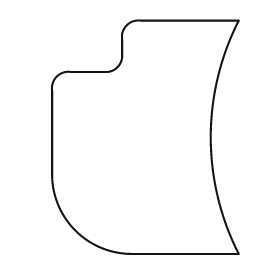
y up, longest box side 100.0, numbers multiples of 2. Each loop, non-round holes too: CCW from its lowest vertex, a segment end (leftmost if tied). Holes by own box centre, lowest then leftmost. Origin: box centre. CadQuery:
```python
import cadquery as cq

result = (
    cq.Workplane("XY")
    .moveTo(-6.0, -50.0)
    .lineTo(40.0, -50.0)
    .threePointArc((28.0, 0.0), (40.0, 50.0))
    .lineTo(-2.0, 50.0)
    .threePointArc((-8.0, 48.0), (-10.0, 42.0))
    .lineTo(-10.0, 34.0)
    .threePointArc((-12.0, 30.0), (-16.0, 28.0))
    .lineTo(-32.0, 28.0)
    .threePointArc((-38.0, 26.0), (-40.0, 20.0))
    .lineTo(-40.0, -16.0)
    .threePointArc((-30.0, -40.0), (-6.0, -50.0))
    .close()
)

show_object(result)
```